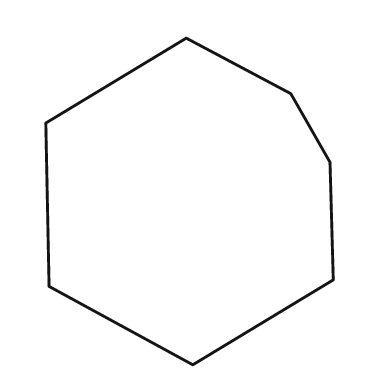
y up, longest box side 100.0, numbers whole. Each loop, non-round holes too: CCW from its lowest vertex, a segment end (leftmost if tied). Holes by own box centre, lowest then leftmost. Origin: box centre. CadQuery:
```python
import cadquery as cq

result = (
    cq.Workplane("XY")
    .moveTo(1.0, -50.0)
    .lineTo(44.0, -24.0)
    .lineTo(43.0, 12.0)
    .lineTo(31.0, 33.0)
    .lineTo(-1.0, 50.0)
    .lineTo(-44.0, 24.0)
    .lineTo(-43.0, -26.0)
    .close()
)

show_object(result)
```